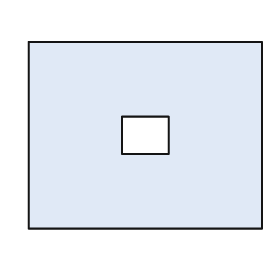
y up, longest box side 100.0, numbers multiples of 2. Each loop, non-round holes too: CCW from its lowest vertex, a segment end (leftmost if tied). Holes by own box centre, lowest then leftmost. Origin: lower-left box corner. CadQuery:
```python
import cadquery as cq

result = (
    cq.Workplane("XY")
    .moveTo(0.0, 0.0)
    .lineTo(100.0, 0.0)
    .lineTo(100.0, 80.0)
    .lineTo(0.0, 80.0)
    .close()
    .moveTo(40.0, 32.0)
    .lineTo(60.0, 32.0)
    .lineTo(60.0, 48.0)
    .lineTo(40.0, 48.0)
    .close()
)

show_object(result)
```